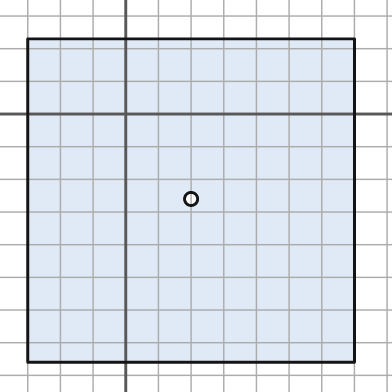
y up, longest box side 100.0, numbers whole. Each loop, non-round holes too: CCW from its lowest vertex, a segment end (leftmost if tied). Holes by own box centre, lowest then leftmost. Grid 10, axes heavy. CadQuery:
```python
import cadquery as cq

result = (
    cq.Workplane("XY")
    .moveTo(-30.0, -76.0)
    .lineTo(70.0, -76.0)
    .lineTo(70.0, 23.0)
    .lineTo(-30.0, 23.0)
    .close()
    .moveTo(20.0, -26.0)
    .circle(2.0)
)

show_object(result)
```